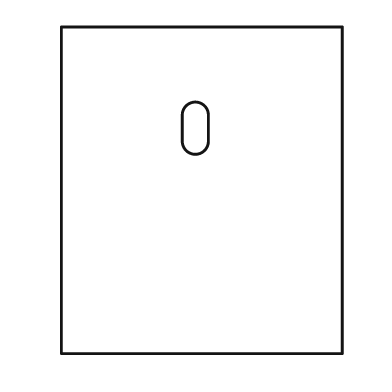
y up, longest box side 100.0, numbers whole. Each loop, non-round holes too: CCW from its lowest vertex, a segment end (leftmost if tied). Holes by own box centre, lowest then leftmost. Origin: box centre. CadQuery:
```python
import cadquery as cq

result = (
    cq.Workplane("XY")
    .moveTo(-43.0, -50.0)
    .lineTo(43.0, -50.0)
    .lineTo(43.0, 50.0)
    .lineTo(-43.0, 50.0)
    .close()
    .moveTo(-6.0, 15.0)
    .threePointArc((-2.0, 11.0), (2.0, 15.0))
    .lineTo(2.0, 23.0)
    .threePointArc((-2.0, 27.0), (-6.0, 23.0))
    .close()
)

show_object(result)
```